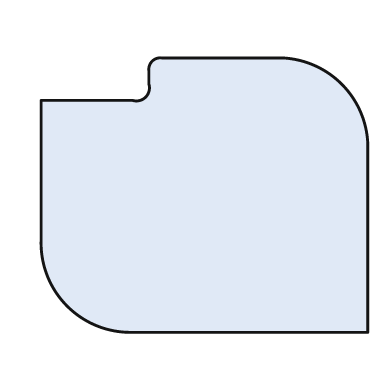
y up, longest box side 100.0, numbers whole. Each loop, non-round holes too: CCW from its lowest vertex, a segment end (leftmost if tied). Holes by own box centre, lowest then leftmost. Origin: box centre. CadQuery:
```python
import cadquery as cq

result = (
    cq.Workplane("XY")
    .moveTo(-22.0, -42.0)
    .lineTo(50.0, -42.0)
    .lineTo(50.0, 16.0)
    .threePointArc((42.0, 34.0), (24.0, 42.0))
    .lineTo(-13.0, 42.0)
    .threePointArc((-16.0, 41.0), (-17.0, 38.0))
    .lineTo(-17.0, 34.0)
    .threePointArc((-18.0, 30.0), (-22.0, 29.0))
    .lineTo(-50.0, 29.0)
    .lineTo(-50.0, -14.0)
    .threePointArc((-42.0, -34.0), (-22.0, -42.0))
    .close()
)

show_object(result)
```